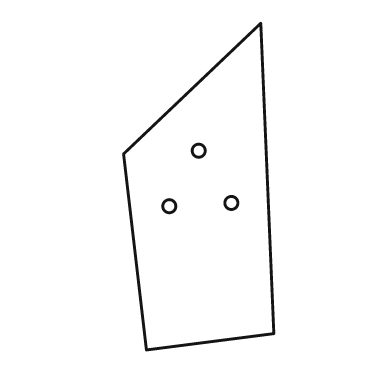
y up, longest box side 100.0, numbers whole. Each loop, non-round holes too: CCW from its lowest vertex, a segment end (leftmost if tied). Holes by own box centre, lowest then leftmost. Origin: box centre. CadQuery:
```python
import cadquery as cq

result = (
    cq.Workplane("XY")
    .moveTo(-16.0, -50.0)
    .lineTo(23.0, -45.0)
    .lineTo(19.0, 50.0)
    .lineTo(-23.0, 10.0)
    .close()
    .moveTo(-9.0, -6.0)
    .circle(2.0)
    .moveTo(10.0, -5.0)
    .circle(2.0)
    .moveTo(0.0, 11.0)
    .circle(2.0)
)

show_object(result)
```